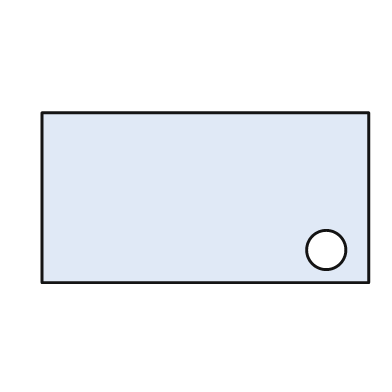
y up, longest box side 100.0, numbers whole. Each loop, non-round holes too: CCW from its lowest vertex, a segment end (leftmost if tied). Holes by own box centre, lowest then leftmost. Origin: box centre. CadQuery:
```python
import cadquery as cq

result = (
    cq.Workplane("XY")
    .moveTo(-50.0, -26.0)
    .lineTo(50.0, -26.0)
    .lineTo(50.0, 26.0)
    .lineTo(-50.0, 26.0)
    .close()
    .moveTo(37.0, -16.0)
    .circle(6.0)
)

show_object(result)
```